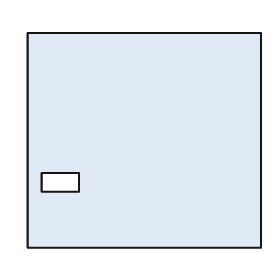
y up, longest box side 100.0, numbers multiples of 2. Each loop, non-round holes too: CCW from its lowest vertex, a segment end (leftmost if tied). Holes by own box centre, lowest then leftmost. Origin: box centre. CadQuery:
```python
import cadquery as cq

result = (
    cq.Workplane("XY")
    .moveTo(-50.0, -46.0)
    .lineTo(50.0, -46.0)
    .lineTo(50.0, 46.0)
    .lineTo(-50.0, 46.0)
    .close()
    .moveTo(-44.0, -22.0)
    .lineTo(-28.0, -22.0)
    .lineTo(-28.0, -14.0)
    .lineTo(-44.0, -14.0)
    .close()
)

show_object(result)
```